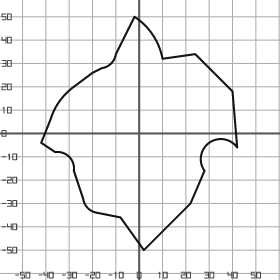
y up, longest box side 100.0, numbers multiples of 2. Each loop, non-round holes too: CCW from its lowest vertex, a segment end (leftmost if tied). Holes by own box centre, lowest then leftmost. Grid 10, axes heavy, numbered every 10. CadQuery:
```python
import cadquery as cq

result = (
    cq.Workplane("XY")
    .moveTo(2.0, -50.0)
    .lineTo(22.0, -30.0)
    .lineTo(28.0, -16.0)
    .threePointArc((30.0, -4.0), (42.0, -6.0))
    .lineTo(40.0, 18.0)
    .lineTo(24.0, 34.0)
    .lineTo(10.0, 32.0)
    .threePointArc((6.0, 42.0), (-2.0, 50.0))
    .lineTo(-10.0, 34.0)
    .threePointArc((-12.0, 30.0), (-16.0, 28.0))
    .lineTo(-20.0, 26.0)
    .lineTo(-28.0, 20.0)
    .threePointArc((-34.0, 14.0), (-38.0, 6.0))
    .lineTo(-42.0, -4.0)
    .lineTo(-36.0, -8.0)
    .threePointArc((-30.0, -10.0), (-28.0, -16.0))
    .lineTo(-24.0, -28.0)
    .threePointArc((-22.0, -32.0), (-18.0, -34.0))
    .lineTo(-8.0, -36.0)
    .close()
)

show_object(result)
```